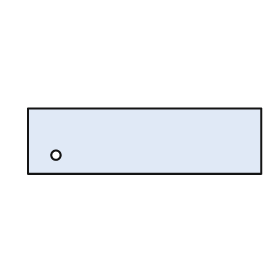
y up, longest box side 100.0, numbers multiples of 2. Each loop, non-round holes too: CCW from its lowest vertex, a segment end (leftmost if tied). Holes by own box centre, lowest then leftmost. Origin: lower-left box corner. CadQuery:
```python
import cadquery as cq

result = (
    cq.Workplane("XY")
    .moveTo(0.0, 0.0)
    .lineTo(100.0, 0.0)
    .lineTo(100.0, 28.0)
    .lineTo(0.0, 28.0)
    .close()
    .moveTo(12.0, 8.0)
    .circle(2.0)
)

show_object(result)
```